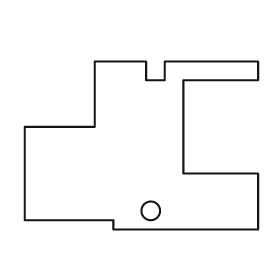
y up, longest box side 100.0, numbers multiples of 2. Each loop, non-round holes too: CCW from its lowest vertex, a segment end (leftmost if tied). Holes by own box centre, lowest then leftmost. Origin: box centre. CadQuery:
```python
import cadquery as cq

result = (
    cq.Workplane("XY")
    .moveTo(-12.0, -36.0)
    .lineTo(50.0, -36.0)
    .lineTo(50.0, -12.0)
    .lineTo(18.0, -12.0)
    .lineTo(18.0, 28.0)
    .lineTo(50.0, 28.0)
    .lineTo(50.0, 36.0)
    .lineTo(10.0, 36.0)
    .lineTo(10.0, 28.0)
    .lineTo(2.0, 28.0)
    .lineTo(2.0, 36.0)
    .lineTo(-20.0, 36.0)
    .lineTo(-20.0, 8.0)
    .lineTo(-50.0, 8.0)
    .lineTo(-50.0, -32.0)
    .lineTo(-12.0, -32.0)
    .close()
    .moveTo(4.0, -28.0)
    .circle(4.0)
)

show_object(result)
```